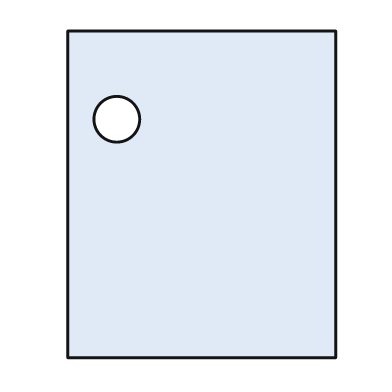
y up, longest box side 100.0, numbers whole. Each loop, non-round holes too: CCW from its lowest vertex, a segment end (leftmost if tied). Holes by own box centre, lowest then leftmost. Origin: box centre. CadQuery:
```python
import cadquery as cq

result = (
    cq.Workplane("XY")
    .moveTo(-41.0, -50.0)
    .lineTo(41.0, -50.0)
    .lineTo(41.0, 50.0)
    .lineTo(-41.0, 50.0)
    .close()
    .moveTo(-26.0, 23.0)
    .circle(7.0)
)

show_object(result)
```